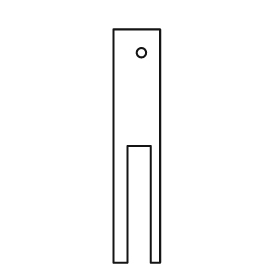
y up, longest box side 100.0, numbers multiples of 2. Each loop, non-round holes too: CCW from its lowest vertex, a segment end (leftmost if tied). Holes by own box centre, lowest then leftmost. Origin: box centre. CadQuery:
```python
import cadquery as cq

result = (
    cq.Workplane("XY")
    .moveTo(-10.0, -50.0)
    .lineTo(-4.0, -50.0)
    .lineTo(-4.0, 0.0)
    .lineTo(6.0, 0.0)
    .lineTo(6.0, -50.0)
    .lineTo(10.0, -50.0)
    .lineTo(10.0, 50.0)
    .lineTo(-10.0, 50.0)
    .close()
    .moveTo(2.0, 40.0)
    .circle(2.0)
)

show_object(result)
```